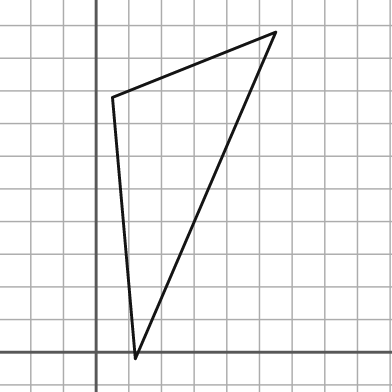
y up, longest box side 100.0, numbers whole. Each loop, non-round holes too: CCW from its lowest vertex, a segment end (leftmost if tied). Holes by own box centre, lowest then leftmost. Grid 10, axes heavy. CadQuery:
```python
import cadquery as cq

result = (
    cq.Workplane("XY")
    .moveTo(12.0, -2.0)
    .lineTo(55.0, 98.0)
    .lineTo(5.0, 78.0)
    .close()
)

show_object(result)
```